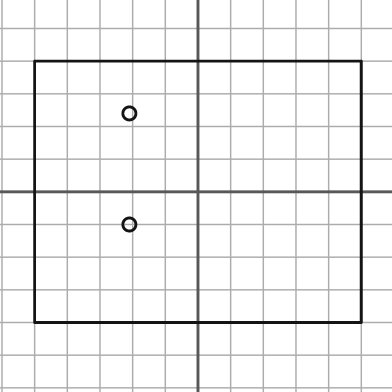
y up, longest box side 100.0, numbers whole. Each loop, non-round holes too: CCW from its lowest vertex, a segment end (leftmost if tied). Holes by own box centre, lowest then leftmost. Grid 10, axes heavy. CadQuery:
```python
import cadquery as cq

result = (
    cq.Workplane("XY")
    .moveTo(-50.0, -40.0)
    .lineTo(50.0, -40.0)
    .lineTo(50.0, 40.0)
    .lineTo(-50.0, 40.0)
    .close()
    .moveTo(-21.0, -10.0)
    .circle(2.0)
    .moveTo(-21.0, 24.0)
    .circle(2.0)
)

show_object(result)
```